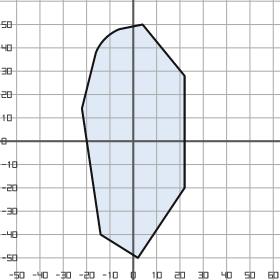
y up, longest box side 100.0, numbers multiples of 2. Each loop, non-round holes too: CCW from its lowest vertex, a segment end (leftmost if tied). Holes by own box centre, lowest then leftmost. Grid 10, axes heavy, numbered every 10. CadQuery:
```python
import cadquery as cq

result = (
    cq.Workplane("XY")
    .moveTo(2.0, -50.0)
    .lineTo(22.0, -20.0)
    .lineTo(22.0, 28.0)
    .lineTo(4.0, 50.0)
    .lineTo(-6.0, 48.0)
    .threePointArc((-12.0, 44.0), (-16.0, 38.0))
    .lineTo(-22.0, 14.0)
    .lineTo(-14.0, -40.0)
    .close()
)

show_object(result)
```